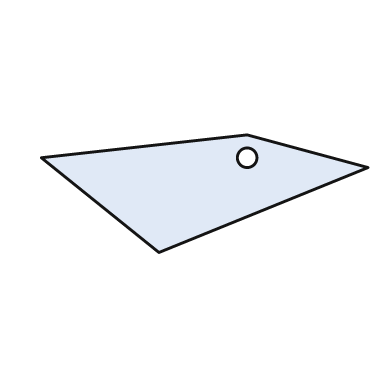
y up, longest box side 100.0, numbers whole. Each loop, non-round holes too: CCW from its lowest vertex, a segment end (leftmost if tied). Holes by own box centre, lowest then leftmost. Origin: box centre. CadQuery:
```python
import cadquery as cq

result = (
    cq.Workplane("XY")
    .moveTo(-14.0, -18.0)
    .lineTo(50.0, 8.0)
    .lineTo(13.0, 18.0)
    .lineTo(-50.0, 11.0)
    .close()
    .moveTo(13.0, 11.0)
    .circle(3.0)
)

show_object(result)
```